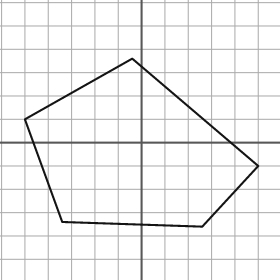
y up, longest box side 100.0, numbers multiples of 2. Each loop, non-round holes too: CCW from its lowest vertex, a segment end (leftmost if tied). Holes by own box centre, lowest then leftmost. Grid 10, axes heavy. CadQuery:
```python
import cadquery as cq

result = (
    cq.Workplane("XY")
    .moveTo(26.0, -36.0)
    .lineTo(50.0, -10.0)
    .lineTo(-4.0, 36.0)
    .lineTo(-50.0, 10.0)
    .lineTo(-34.0, -34.0)
    .close()
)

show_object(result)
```